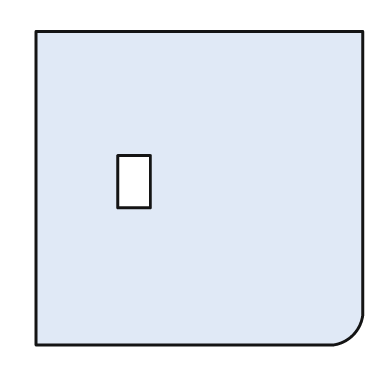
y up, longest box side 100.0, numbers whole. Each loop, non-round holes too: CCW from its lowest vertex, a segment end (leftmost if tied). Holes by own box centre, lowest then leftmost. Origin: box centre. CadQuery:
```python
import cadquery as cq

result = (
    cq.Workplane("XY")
    .moveTo(-50.0, -48.0)
    .lineTo(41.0, -48.0)
    .threePointArc((47.0, -45.0), (50.0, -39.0))
    .lineTo(50.0, 48.0)
    .lineTo(-50.0, 48.0)
    .close()
    .moveTo(-25.0, -6.0)
    .lineTo(-15.0, -6.0)
    .lineTo(-15.0, 10.0)
    .lineTo(-25.0, 10.0)
    .close()
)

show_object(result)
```